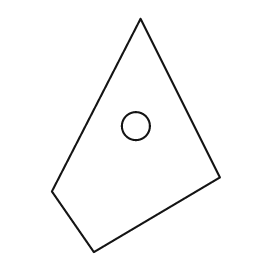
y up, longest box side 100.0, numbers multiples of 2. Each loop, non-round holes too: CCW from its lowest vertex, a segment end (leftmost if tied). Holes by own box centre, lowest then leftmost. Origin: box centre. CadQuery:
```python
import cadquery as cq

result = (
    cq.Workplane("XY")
    .moveTo(-18.0, -50.0)
    .lineTo(36.0, -18.0)
    .lineTo(2.0, 50.0)
    .lineTo(-36.0, -24.0)
    .close()
    .moveTo(0.0, 4.0)
    .circle(6.0)
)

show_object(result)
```